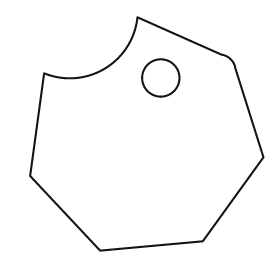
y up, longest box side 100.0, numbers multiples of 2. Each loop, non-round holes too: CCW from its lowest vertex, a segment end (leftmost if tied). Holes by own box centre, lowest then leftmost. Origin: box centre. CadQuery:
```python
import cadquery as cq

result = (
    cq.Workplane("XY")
    .moveTo(-20.0, -50.0)
    .lineTo(24.0, -46.0)
    .lineTo(50.0, -10.0)
    .lineTo(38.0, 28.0)
    .threePointArc((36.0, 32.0), (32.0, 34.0))
    .lineTo(-4.0, 50.0)
    .threePointArc((-18.0, 28.0), (-44.0, 26.0))
    .lineTo(-50.0, -18.0)
    .close()
    .moveTo(6.0, 24.0)
    .circle(8.0)
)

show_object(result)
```